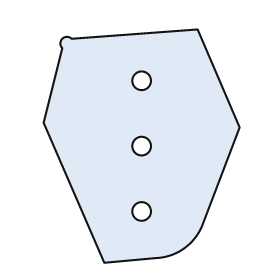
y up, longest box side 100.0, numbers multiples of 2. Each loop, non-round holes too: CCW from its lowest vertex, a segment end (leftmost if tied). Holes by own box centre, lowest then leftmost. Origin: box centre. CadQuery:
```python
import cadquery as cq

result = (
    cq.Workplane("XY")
    .moveTo(-16.0, -50.0)
    .lineTo(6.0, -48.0)
    .threePointArc((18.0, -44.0), (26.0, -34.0))
    .lineTo(42.0, 8.0)
    .lineTo(24.0, 50.0)
    .lineTo(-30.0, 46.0)
    .threePointArc((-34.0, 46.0), (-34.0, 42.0))
    .lineTo(-42.0, 10.0)
    .close()
    .moveTo(0.0, -28.0)
    .circle(4.0)
    .moveTo(0.0, 0.0)
    .circle(4.0)
    .moveTo(0.0, 28.0)
    .circle(4.0)
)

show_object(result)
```